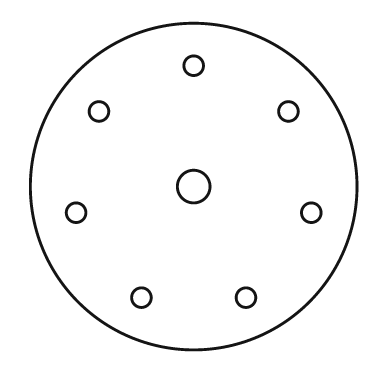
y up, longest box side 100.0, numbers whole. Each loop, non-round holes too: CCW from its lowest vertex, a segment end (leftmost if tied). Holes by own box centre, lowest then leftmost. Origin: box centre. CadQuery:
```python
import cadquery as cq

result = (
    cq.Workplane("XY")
    .moveTo(0.0, 0.0)
    .circle(50.0)
    .moveTo(-16.0, -34.0)
    .circle(3.0)
    .moveTo(16.0, -34.0)
    .circle(3.0)
    .moveTo(-36.0, -8.0)
    .circle(3.0)
    .moveTo(36.0, -8.0)
    .circle(3.0)
    .moveTo(0.0, 0.0)
    .circle(5.0)
    .moveTo(-29.0, 23.0)
    .circle(3.0)
    .moveTo(29.0, 23.0)
    .circle(3.0)
    .moveTo(0.0, 37.0)
    .circle(3.0)
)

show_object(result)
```